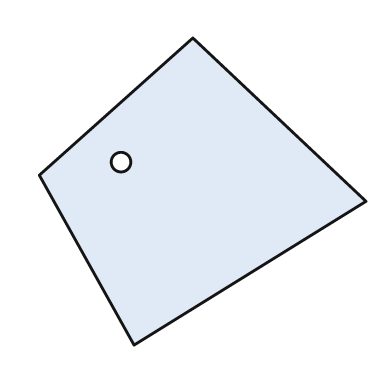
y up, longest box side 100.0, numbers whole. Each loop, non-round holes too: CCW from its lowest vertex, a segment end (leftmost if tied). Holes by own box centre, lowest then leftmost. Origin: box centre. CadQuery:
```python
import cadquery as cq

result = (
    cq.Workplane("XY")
    .moveTo(-21.0, -47.0)
    .lineTo(50.0, -3.0)
    .lineTo(-3.0, 47.0)
    .lineTo(-50.0, 5.0)
    .close()
    .moveTo(-25.0, 9.0)
    .circle(3.0)
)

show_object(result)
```